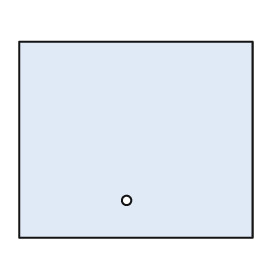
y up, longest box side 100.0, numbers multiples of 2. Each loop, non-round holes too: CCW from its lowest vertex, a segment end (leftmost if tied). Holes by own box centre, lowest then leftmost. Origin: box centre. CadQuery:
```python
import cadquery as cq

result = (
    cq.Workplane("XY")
    .moveTo(-50.0, -42.0)
    .lineTo(50.0, -42.0)
    .lineTo(50.0, 42.0)
    .lineTo(-50.0, 42.0)
    .close()
    .moveTo(-4.0, -26.0)
    .circle(2.0)
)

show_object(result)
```